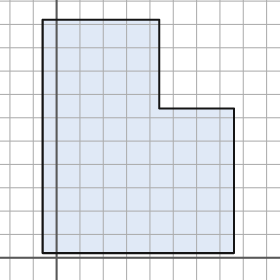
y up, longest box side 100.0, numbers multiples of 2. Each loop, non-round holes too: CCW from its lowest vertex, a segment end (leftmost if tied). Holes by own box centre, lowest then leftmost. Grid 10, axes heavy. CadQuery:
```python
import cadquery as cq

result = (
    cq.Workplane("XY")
    .moveTo(-6.0, 2.0)
    .lineTo(76.0, 2.0)
    .lineTo(76.0, 64.0)
    .lineTo(44.0, 64.0)
    .lineTo(44.0, 102.0)
    .lineTo(-6.0, 102.0)
    .close()
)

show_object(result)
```